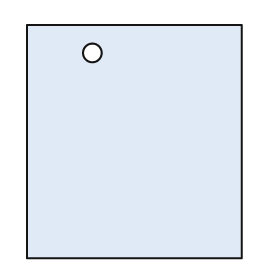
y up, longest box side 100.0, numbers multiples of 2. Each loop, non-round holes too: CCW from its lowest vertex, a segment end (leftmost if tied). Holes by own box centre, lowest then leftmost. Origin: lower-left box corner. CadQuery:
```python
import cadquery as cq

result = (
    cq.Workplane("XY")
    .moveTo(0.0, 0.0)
    .lineTo(92.0, 0.0)
    .lineTo(92.0, 100.0)
    .lineTo(0.0, 100.0)
    .close()
    .moveTo(28.0, 88.0)
    .circle(4.0)
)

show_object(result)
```